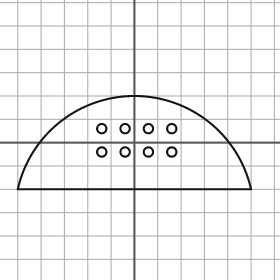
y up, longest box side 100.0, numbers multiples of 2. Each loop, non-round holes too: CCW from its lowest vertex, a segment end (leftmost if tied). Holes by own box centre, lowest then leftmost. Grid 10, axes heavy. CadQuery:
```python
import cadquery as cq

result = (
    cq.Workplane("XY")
    .moveTo(-50.0, -20.0)
    .lineTo(50.0, -20.0)
    .threePointArc((0.0, 20.0), (-50.0, -20.0))
    .close()
    .moveTo(-14.0, -4.0)
    .circle(2.0)
    .moveTo(-4.0, -4.0)
    .circle(2.0)
    .moveTo(6.0, -4.0)
    .circle(2.0)
    .moveTo(16.0, -4.0)
    .circle(2.0)
    .moveTo(-14.0, 6.0)
    .circle(2.0)
    .moveTo(-4.0, 6.0)
    .circle(2.0)
    .moveTo(6.0, 6.0)
    .circle(2.0)
    .moveTo(16.0, 6.0)
    .circle(2.0)
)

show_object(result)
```